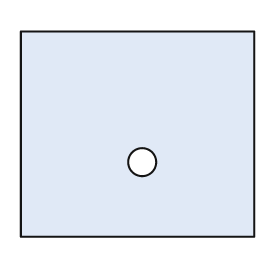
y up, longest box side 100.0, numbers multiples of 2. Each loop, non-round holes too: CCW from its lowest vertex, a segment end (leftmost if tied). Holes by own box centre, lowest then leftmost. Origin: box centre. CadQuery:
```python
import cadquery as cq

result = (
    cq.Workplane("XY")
    .moveTo(-50.0, -44.0)
    .lineTo(50.0, -44.0)
    .lineTo(50.0, 44.0)
    .lineTo(-50.0, 44.0)
    .close()
    .moveTo(2.0, -12.0)
    .circle(6.0)
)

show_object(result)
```